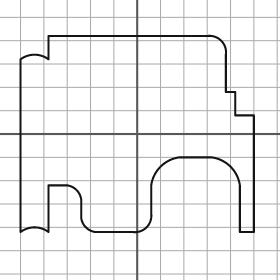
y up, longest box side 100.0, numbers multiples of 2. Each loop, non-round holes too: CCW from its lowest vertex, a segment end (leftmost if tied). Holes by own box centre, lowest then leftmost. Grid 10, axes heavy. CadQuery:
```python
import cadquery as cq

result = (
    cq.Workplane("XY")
    .moveTo(-50.0, -42.0)
    .threePointArc((-44.0, -40.0), (-38.0, -42.0))
    .lineTo(-38.0, -22.0)
    .lineTo(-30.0, -22.0)
    .threePointArc((-26.0, -24.0), (-24.0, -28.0))
    .lineTo(-24.0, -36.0)
    .threePointArc((-22.0, -40.0), (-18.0, -42.0))
    .lineTo(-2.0, -42.0)
    .threePointArc((4.0, -40.0), (6.0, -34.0))
    .lineTo(6.0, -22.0)
    .threePointArc((10.0, -14.0), (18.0, -10.0))
    .lineTo(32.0, -10.0)
    .threePointArc((40.0, -14.0), (44.0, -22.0))
    .lineTo(44.0, -42.0)
    .lineTo(50.0, -42.0)
    .lineTo(50.0, 8.0)
    .lineTo(42.0, 8.0)
    .lineTo(42.0, 18.0)
    .lineTo(38.0, 18.0)
    .lineTo(38.0, 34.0)
    .threePointArc((36.0, 40.0), (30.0, 42.0))
    .lineTo(-38.0, 42.0)
    .lineTo(-38.0, 32.0)
    .threePointArc((-44.0, 34.0), (-50.0, 32.0))
    .close()
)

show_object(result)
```